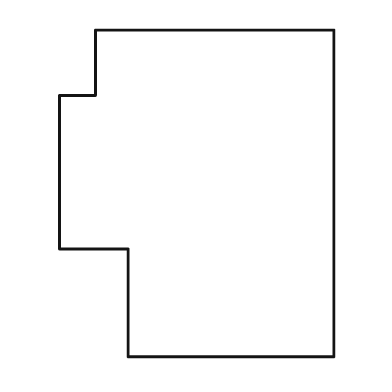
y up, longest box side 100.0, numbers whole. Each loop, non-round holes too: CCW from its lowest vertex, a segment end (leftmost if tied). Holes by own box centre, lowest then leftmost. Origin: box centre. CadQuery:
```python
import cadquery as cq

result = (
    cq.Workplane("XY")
    .moveTo(-21.0, -50.0)
    .lineTo(42.0, -50.0)
    .lineTo(42.0, 50.0)
    .lineTo(-31.0, 50.0)
    .lineTo(-31.0, 30.0)
    .lineTo(-42.0, 30.0)
    .lineTo(-42.0, -17.0)
    .lineTo(-21.0, -17.0)
    .close()
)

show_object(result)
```